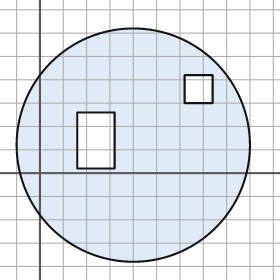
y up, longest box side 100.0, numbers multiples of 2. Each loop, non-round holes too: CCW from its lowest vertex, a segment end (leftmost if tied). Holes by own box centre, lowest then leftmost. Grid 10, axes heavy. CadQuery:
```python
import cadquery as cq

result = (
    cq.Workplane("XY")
    .moveTo(40.0, 12.0)
    .circle(50.0)
    .moveTo(16.0, 2.0)
    .lineTo(32.0, 2.0)
    .lineTo(32.0, 26.0)
    .lineTo(16.0, 26.0)
    .close()
    .moveTo(62.0, 30.0)
    .lineTo(74.0, 30.0)
    .lineTo(74.0, 42.0)
    .lineTo(62.0, 42.0)
    .close()
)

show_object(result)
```